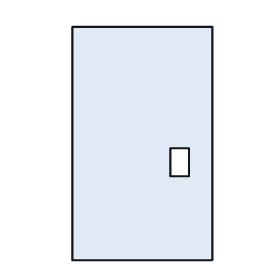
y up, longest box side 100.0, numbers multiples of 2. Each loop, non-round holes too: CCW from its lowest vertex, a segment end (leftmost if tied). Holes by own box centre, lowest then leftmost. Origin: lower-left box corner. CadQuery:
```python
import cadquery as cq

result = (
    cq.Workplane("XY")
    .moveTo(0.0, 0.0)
    .lineTo(60.0, 0.0)
    .lineTo(60.0, 100.0)
    .lineTo(0.0, 100.0)
    .close()
    .moveTo(42.0, 36.0)
    .lineTo(50.0, 36.0)
    .lineTo(50.0, 48.0)
    .lineTo(42.0, 48.0)
    .close()
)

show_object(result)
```